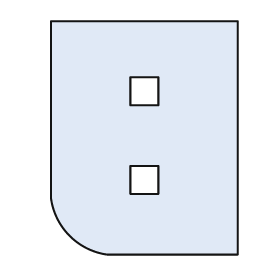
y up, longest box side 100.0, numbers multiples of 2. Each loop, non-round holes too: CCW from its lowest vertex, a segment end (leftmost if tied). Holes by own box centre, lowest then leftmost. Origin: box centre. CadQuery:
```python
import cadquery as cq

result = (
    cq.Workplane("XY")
    .moveTo(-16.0, -50.0)
    .lineTo(40.0, -50.0)
    .lineTo(40.0, 50.0)
    .lineTo(-40.0, 50.0)
    .lineTo(-40.0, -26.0)
    .threePointArc((-32.0, -42.0), (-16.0, -50.0))
    .close()
    .moveTo(-6.0, -24.0)
    .lineTo(6.0, -24.0)
    .lineTo(6.0, -12.0)
    .lineTo(-6.0, -12.0)
    .close()
    .moveTo(-6.0, 14.0)
    .lineTo(6.0, 14.0)
    .lineTo(6.0, 26.0)
    .lineTo(-6.0, 26.0)
    .close()
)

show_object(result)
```